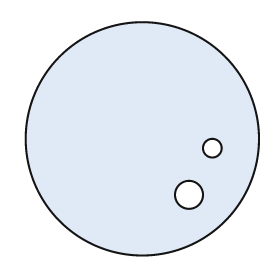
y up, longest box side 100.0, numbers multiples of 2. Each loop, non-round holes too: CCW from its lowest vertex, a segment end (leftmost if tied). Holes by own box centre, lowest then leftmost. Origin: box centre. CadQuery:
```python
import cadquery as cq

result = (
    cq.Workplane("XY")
    .moveTo(0.0, 0.0)
    .circle(50.0)
    .moveTo(20.0, -24.0)
    .circle(6.0)
    .moveTo(30.0, -4.0)
    .circle(4.0)
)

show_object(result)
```